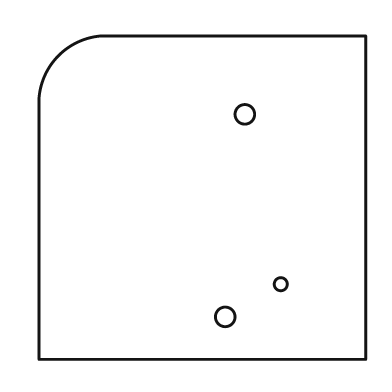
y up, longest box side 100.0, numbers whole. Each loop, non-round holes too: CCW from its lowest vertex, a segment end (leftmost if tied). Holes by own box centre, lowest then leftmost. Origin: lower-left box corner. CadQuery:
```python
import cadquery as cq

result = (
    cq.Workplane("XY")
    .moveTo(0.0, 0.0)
    .lineTo(100.0, 0.0)
    .lineTo(100.0, 99.0)
    .lineTo(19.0, 99.0)
    .threePointArc((6.0, 93.0), (0.0, 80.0))
    .close()
    .moveTo(57.0, 13.0)
    .circle(3.0)
    .moveTo(74.0, 23.0)
    .circle(2.0)
    .moveTo(63.0, 75.0)
    .circle(3.0)
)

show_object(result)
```